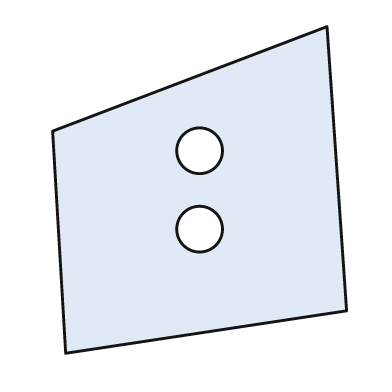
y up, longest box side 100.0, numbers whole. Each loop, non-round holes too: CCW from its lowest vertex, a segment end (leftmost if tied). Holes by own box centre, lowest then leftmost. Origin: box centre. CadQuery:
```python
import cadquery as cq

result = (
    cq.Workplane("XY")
    .moveTo(-41.0, -50.0)
    .lineTo(45.0, -37.0)
    .lineTo(39.0, 50.0)
    .lineTo(-45.0, 18.0)
    .close()
    .moveTo(0.0, -12.0)
    .circle(7.0)
    .moveTo(0.0, 12.0)
    .circle(7.0)
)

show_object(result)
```